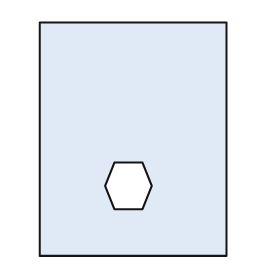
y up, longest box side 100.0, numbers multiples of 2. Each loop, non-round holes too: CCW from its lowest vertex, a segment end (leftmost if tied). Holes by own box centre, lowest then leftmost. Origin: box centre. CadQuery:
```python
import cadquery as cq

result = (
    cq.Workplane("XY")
    .moveTo(-40.0, -50.0)
    .lineTo(40.0, -50.0)
    .lineTo(40.0, 50.0)
    .lineTo(-40.0, 50.0)
    .close()
    .moveTo(-8.0, -30.0)
    .lineTo(4.0, -30.0)
    .lineTo(8.0, -20.0)
    .lineTo(4.0, -10.0)
    .lineTo(-8.0, -10.0)
    .lineTo(-12.0, -20.0)
    .close()
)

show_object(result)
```